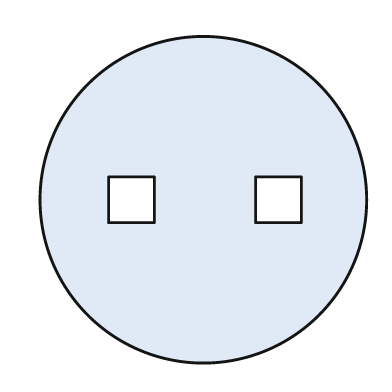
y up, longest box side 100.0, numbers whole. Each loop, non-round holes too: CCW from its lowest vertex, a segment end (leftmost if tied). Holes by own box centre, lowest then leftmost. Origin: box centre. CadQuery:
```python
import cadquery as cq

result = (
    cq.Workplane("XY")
    .moveTo(0.0, 0.0)
    .circle(50.0)
    .moveTo(-29.0, -7.0)
    .lineTo(-15.0, -7.0)
    .lineTo(-15.0, 7.0)
    .lineTo(-29.0, 7.0)
    .close()
    .moveTo(16.0, -7.0)
    .lineTo(30.0, -7.0)
    .lineTo(30.0, 7.0)
    .lineTo(16.0, 7.0)
    .close()
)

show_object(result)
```